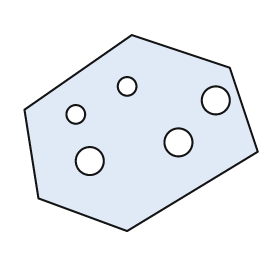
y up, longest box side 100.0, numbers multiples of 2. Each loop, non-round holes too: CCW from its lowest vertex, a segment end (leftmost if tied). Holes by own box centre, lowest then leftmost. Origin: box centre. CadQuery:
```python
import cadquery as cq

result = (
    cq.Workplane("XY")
    .moveTo(-6.0, -42.0)
    .lineTo(50.0, -8.0)
    .lineTo(38.0, 28.0)
    .lineTo(-4.0, 42.0)
    .lineTo(-50.0, 10.0)
    .lineTo(-44.0, -28.0)
    .close()
    .moveTo(-22.0, -12.0)
    .circle(6.0)
    .moveTo(16.0, -4.0)
    .circle(6.0)
    .moveTo(-28.0, 8.0)
    .circle(4.0)
    .moveTo(32.0, 14.0)
    .circle(6.0)
    .moveTo(-6.0, 20.0)
    .circle(4.0)
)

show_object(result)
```